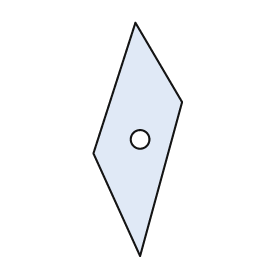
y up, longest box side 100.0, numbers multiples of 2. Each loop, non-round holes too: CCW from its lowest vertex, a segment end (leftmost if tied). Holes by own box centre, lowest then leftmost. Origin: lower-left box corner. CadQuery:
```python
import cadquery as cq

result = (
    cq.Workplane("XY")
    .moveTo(20.0, 0.0)
    .lineTo(38.0, 66.0)
    .lineTo(18.0, 100.0)
    .lineTo(0.0, 44.0)
    .close()
    .moveTo(20.0, 50.0)
    .circle(4.0)
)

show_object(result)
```